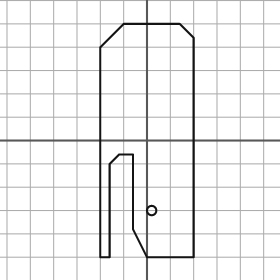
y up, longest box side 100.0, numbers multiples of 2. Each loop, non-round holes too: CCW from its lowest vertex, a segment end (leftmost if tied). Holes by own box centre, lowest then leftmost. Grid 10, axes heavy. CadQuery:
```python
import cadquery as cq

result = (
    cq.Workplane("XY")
    .moveTo(-20.0, -50.0)
    .lineTo(-16.0, -50.0)
    .lineTo(-16.0, -10.0)
    .lineTo(-12.0, -6.0)
    .lineTo(-6.0, -6.0)
    .lineTo(-6.0, -38.0)
    .lineTo(0.0, -50.0)
    .lineTo(20.0, -50.0)
    .lineTo(20.0, 44.0)
    .lineTo(14.0, 50.0)
    .lineTo(-10.0, 50.0)
    .lineTo(-20.0, 40.0)
    .close()
    .moveTo(2.0, -30.0)
    .circle(2.0)
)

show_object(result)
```